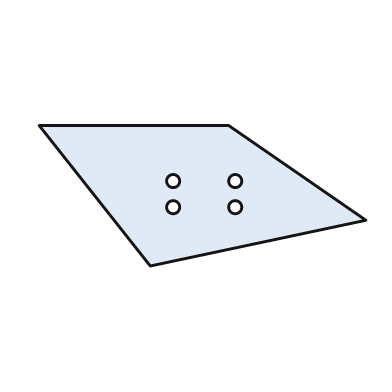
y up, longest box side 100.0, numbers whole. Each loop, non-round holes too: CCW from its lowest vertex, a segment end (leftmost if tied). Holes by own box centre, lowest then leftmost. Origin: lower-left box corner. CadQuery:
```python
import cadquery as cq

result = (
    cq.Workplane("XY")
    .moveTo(34.0, 0.0)
    .lineTo(100.0, 14.0)
    .lineTo(58.0, 43.0)
    .lineTo(0.0, 43.0)
    .close()
    .moveTo(41.0, 18.0)
    .circle(2.0)
    .moveTo(60.0, 18.0)
    .circle(2.0)
    .moveTo(41.0, 26.0)
    .circle(2.0)
    .moveTo(60.0, 26.0)
    .circle(2.0)
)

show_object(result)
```